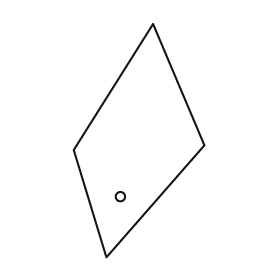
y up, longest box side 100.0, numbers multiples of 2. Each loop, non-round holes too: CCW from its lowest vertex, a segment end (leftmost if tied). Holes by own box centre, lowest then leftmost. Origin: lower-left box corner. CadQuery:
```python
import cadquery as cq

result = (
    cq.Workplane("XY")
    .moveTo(14.0, 0.0)
    .lineTo(56.0, 48.0)
    .lineTo(34.0, 100.0)
    .lineTo(0.0, 46.0)
    .close()
    .moveTo(20.0, 26.0)
    .circle(2.0)
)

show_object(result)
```